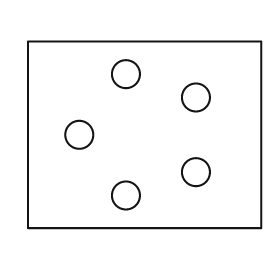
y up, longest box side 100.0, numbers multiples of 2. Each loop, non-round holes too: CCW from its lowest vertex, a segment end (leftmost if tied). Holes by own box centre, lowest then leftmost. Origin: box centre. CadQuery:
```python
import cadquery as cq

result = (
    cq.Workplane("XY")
    .moveTo(-50.0, -40.0)
    .lineTo(50.0, -40.0)
    .lineTo(50.0, 40.0)
    .lineTo(-50.0, 40.0)
    .close()
    .moveTo(-8.0, -26.0)
    .circle(6.0)
    .moveTo(22.0, -16.0)
    .circle(6.0)
    .moveTo(-28.0, 0.0)
    .circle(6.0)
    .moveTo(22.0, 16.0)
    .circle(6.0)
    .moveTo(-8.0, 26.0)
    .circle(6.0)
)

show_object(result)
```